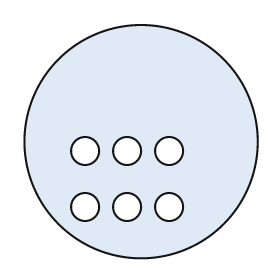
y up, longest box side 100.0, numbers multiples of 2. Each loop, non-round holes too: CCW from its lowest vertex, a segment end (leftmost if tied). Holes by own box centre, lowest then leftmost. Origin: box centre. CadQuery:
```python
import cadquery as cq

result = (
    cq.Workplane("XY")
    .moveTo(0.0, 0.0)
    .circle(50.0)
    .moveTo(-24.0, -28.0)
    .circle(6.0)
    .moveTo(-6.0, -28.0)
    .circle(6.0)
    .moveTo(12.0, -28.0)
    .circle(6.0)
    .moveTo(-24.0, -4.0)
    .circle(6.0)
    .moveTo(-6.0, -4.0)
    .circle(6.0)
    .moveTo(12.0, -4.0)
    .circle(6.0)
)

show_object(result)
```